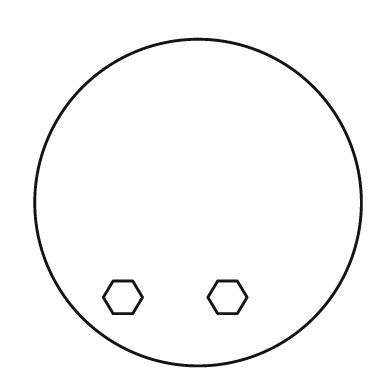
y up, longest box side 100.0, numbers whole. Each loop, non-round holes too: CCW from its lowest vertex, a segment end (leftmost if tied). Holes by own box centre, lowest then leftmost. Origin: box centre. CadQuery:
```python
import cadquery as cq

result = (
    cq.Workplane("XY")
    .moveTo(0.0, 0.0)
    .circle(50.0)
    .moveTo(-26.0, -34.0)
    .lineTo(-20.0, -34.0)
    .lineTo(-17.0, -29.0)
    .lineTo(-20.0, -24.0)
    .lineTo(-26.0, -24.0)
    .lineTo(-29.0, -29.0)
    .close()
    .moveTo(6.0, -34.0)
    .lineTo(12.0, -34.0)
    .lineTo(15.0, -29.0)
    .lineTo(12.0, -24.0)
    .lineTo(6.0, -24.0)
    .lineTo(3.0, -29.0)
    .close()
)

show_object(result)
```